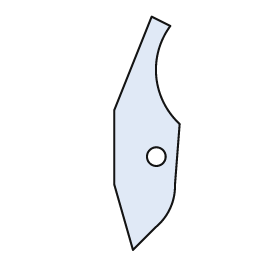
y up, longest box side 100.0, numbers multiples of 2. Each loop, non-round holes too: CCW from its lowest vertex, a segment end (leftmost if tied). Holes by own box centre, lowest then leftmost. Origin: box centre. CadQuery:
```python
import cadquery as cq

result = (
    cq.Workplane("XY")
    .moveTo(-6.0, -50.0)
    .lineTo(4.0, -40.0)
    .threePointArc((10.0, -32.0), (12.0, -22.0))
    .lineTo(14.0, 4.0)
    .threePointArc((4.0, 24.0), (10.0, 46.0))
    .lineTo(2.0, 50.0)
    .lineTo(-14.0, 10.0)
    .lineTo(-14.0, -22.0)
    .close()
    .moveTo(4.0, -10.0)
    .circle(4.0)
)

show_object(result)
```